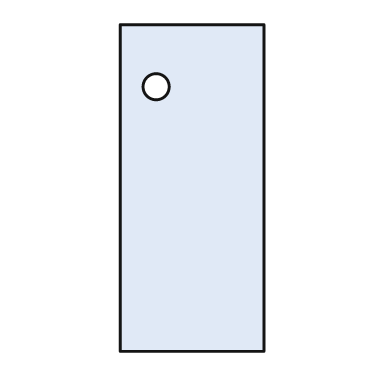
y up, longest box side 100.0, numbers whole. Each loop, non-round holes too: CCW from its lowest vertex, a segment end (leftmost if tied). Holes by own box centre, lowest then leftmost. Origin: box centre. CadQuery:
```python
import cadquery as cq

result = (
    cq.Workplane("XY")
    .moveTo(-22.0, -50.0)
    .lineTo(22.0, -50.0)
    .lineTo(22.0, 50.0)
    .lineTo(-22.0, 50.0)
    .close()
    .moveTo(-11.0, 31.0)
    .circle(4.0)
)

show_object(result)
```